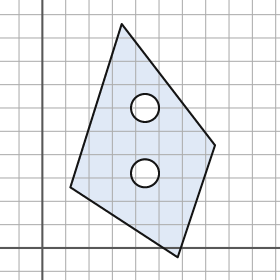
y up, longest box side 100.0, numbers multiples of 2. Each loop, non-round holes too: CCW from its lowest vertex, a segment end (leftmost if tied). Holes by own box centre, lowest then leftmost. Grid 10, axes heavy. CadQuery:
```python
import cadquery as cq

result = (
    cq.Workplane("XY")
    .moveTo(58.0, -4.0)
    .lineTo(74.0, 44.0)
    .lineTo(34.0, 96.0)
    .lineTo(12.0, 26.0)
    .close()
    .moveTo(44.0, 32.0)
    .circle(6.0)
    .moveTo(44.0, 60.0)
    .circle(6.0)
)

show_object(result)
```